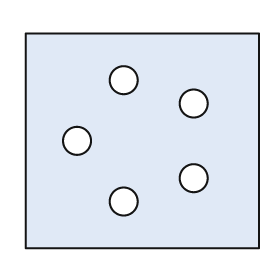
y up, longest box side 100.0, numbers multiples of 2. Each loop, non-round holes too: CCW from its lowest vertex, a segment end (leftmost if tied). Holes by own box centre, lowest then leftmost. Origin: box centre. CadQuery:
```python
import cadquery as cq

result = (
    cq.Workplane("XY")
    .moveTo(-50.0, -46.0)
    .lineTo(50.0, -46.0)
    .lineTo(50.0, 46.0)
    .lineTo(-50.0, 46.0)
    .close()
    .moveTo(-8.0, -26.0)
    .circle(6.0)
    .moveTo(22.0, -16.0)
    .circle(6.0)
    .moveTo(-28.0, 0.0)
    .circle(6.0)
    .moveTo(22.0, 16.0)
    .circle(6.0)
    .moveTo(-8.0, 26.0)
    .circle(6.0)
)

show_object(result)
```